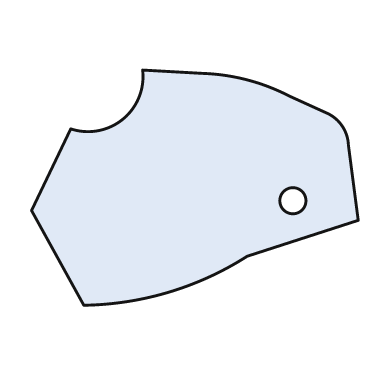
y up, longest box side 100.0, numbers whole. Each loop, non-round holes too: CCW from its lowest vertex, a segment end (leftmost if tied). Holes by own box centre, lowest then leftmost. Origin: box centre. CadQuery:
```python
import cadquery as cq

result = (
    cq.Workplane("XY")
    .moveTo(-34.0, -36.0)
    .threePointArc((-8.0, -32.0), (16.0, -21.0))
    .lineTo(50.0, -10.0)
    .lineTo(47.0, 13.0)
    .threePointArc((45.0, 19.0), (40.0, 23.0))
    .lineTo(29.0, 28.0)
    .threePointArc((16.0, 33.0), (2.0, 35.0))
    .lineTo(-16.0, 36.0)
    .threePointArc((-22.0, 21.0), (-38.0, 18.0))
    .lineTo(-50.0, -7.0)
    .close()
    .moveTo(30.0, -4.0)
    .circle(4.0)
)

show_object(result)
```